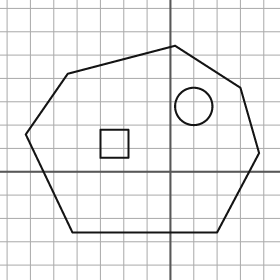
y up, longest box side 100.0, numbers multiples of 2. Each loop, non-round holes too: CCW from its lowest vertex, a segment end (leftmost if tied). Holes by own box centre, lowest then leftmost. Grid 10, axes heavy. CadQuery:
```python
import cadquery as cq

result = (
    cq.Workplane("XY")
    .moveTo(-42.0, -26.0)
    .lineTo(20.0, -26.0)
    .lineTo(38.0, 8.0)
    .lineTo(30.0, 36.0)
    .lineTo(2.0, 54.0)
    .lineTo(-44.0, 42.0)
    .lineTo(-62.0, 16.0)
    .close()
    .moveTo(-30.0, 6.0)
    .lineTo(-18.0, 6.0)
    .lineTo(-18.0, 18.0)
    .lineTo(-30.0, 18.0)
    .close()
    .moveTo(10.0, 28.0)
    .circle(8.0)
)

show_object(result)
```